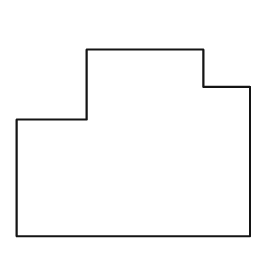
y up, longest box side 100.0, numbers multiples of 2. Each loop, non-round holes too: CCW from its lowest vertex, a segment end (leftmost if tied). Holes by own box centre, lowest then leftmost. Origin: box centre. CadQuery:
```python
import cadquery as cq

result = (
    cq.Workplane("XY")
    .moveTo(-50.0, -40.0)
    .lineTo(50.0, -40.0)
    .lineTo(50.0, 24.0)
    .lineTo(30.0, 24.0)
    .lineTo(30.0, 40.0)
    .lineTo(-20.0, 40.0)
    .lineTo(-20.0, 10.0)
    .lineTo(-50.0, 10.0)
    .close()
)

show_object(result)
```